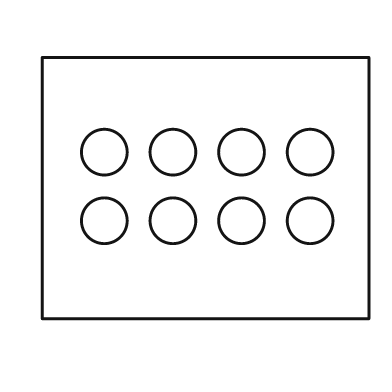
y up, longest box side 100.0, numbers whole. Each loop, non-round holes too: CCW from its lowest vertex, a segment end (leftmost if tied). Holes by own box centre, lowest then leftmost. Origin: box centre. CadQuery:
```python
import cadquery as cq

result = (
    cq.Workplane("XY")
    .moveTo(-50.0, -40.0)
    .lineTo(50.0, -40.0)
    .lineTo(50.0, 40.0)
    .lineTo(-50.0, 40.0)
    .close()
    .moveTo(-31.0, -10.0)
    .circle(7.0)
    .moveTo(-10.0, -10.0)
    .circle(7.0)
    .moveTo(11.0, -10.0)
    .circle(7.0)
    .moveTo(32.0, -10.0)
    .circle(7.0)
    .moveTo(-31.0, 11.0)
    .circle(7.0)
    .moveTo(-10.0, 11.0)
    .circle(7.0)
    .moveTo(11.0, 11.0)
    .circle(7.0)
    .moveTo(32.0, 11.0)
    .circle(7.0)
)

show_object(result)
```